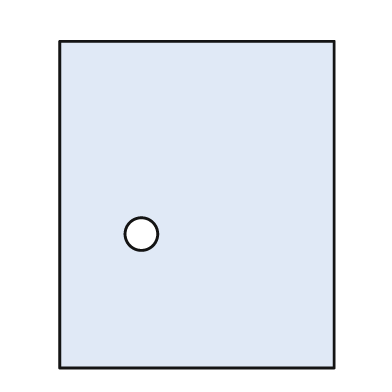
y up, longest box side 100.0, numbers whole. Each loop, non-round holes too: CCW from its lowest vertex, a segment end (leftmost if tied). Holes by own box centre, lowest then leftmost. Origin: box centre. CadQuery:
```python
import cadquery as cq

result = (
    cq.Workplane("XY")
    .moveTo(-42.0, -50.0)
    .lineTo(42.0, -50.0)
    .lineTo(42.0, 50.0)
    .lineTo(-42.0, 50.0)
    .close()
    .moveTo(-17.0, -9.0)
    .circle(5.0)
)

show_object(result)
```